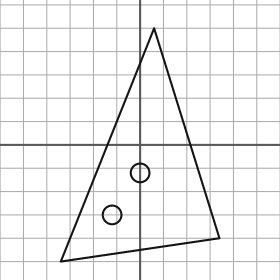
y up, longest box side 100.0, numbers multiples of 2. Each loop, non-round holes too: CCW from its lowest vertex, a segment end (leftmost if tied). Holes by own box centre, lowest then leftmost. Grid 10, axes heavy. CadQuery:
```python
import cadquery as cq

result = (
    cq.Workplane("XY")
    .moveTo(-34.0, -50.0)
    .lineTo(34.0, -40.0)
    .lineTo(6.0, 50.0)
    .close()
    .moveTo(-12.0, -30.0)
    .circle(4.0)
    .moveTo(0.0, -12.0)
    .circle(4.0)
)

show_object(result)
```